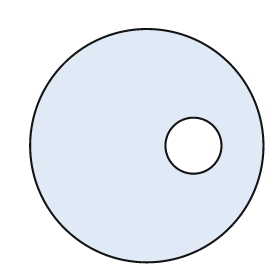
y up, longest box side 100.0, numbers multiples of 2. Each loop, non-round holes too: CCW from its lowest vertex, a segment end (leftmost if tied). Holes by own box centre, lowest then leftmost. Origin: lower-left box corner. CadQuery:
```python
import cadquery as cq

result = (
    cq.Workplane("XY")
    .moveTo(50.0, 50.0)
    .circle(50.0)
    .moveTo(70.0, 50.0)
    .circle(12.0)
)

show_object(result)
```